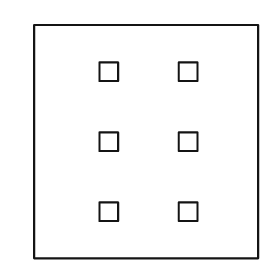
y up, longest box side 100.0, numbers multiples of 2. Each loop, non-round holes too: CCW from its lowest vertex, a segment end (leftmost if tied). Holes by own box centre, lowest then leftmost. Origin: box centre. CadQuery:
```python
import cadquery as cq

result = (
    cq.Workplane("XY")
    .moveTo(-48.0, -50.0)
    .lineTo(48.0, -50.0)
    .lineTo(48.0, 50.0)
    .lineTo(-48.0, 50.0)
    .close()
    .moveTo(-20.0, -34.0)
    .lineTo(-12.0, -34.0)
    .lineTo(-12.0, -26.0)
    .lineTo(-20.0, -26.0)
    .close()
    .moveTo(14.0, -34.0)
    .lineTo(22.0, -34.0)
    .lineTo(22.0, -26.0)
    .lineTo(14.0, -26.0)
    .close()
    .moveTo(-20.0, -4.0)
    .lineTo(-12.0, -4.0)
    .lineTo(-12.0, 4.0)
    .lineTo(-20.0, 4.0)
    .close()
    .moveTo(14.0, -4.0)
    .lineTo(22.0, -4.0)
    .lineTo(22.0, 4.0)
    .lineTo(14.0, 4.0)
    .close()
    .moveTo(-20.0, 26.0)
    .lineTo(-12.0, 26.0)
    .lineTo(-12.0, 34.0)
    .lineTo(-20.0, 34.0)
    .close()
    .moveTo(14.0, 26.0)
    .lineTo(22.0, 26.0)
    .lineTo(22.0, 34.0)
    .lineTo(14.0, 34.0)
    .close()
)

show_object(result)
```